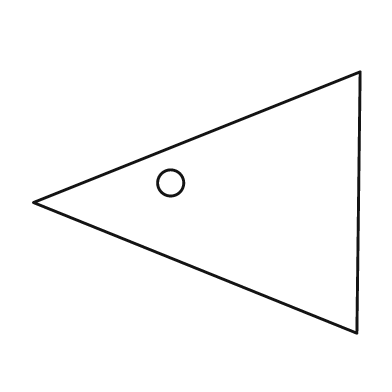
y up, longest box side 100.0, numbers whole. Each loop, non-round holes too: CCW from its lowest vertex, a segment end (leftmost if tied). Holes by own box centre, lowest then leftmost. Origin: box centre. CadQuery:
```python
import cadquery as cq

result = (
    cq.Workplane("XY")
    .moveTo(49.0, -40.0)
    .lineTo(50.0, 40.0)
    .lineTo(-50.0, 0.0)
    .close()
    .moveTo(-8.0, 6.0)
    .circle(4.0)
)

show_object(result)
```